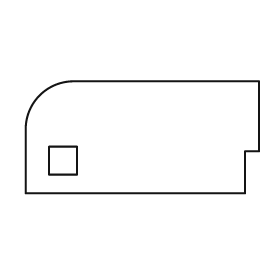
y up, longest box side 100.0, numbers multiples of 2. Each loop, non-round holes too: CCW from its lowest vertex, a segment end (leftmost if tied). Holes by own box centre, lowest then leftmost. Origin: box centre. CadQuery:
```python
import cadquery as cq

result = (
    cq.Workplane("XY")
    .moveTo(-50.0, -24.0)
    .lineTo(44.0, -24.0)
    .lineTo(44.0, -6.0)
    .lineTo(50.0, -6.0)
    .lineTo(50.0, 24.0)
    .lineTo(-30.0, 24.0)
    .threePointArc((-44.0, 18.0), (-50.0, 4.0))
    .close()
    .moveTo(-40.0, -16.0)
    .lineTo(-28.0, -16.0)
    .lineTo(-28.0, -4.0)
    .lineTo(-40.0, -4.0)
    .close()
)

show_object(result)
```